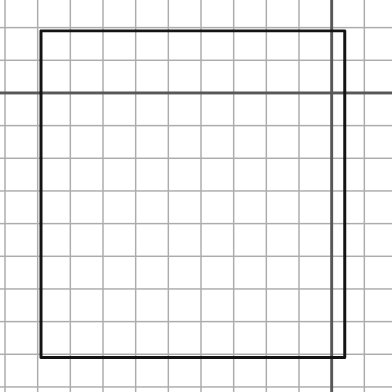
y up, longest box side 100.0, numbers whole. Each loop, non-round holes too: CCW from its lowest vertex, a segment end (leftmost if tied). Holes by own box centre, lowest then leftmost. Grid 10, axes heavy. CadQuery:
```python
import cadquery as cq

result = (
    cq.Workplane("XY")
    .moveTo(-89.0, -81.0)
    .lineTo(4.0, -81.0)
    .lineTo(4.0, 19.0)
    .lineTo(-89.0, 19.0)
    .close()
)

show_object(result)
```